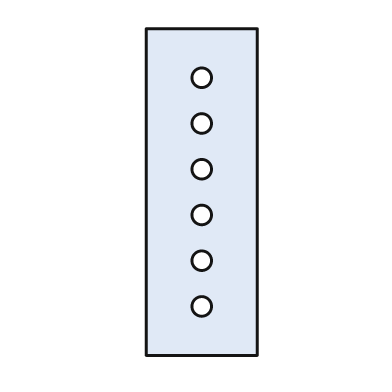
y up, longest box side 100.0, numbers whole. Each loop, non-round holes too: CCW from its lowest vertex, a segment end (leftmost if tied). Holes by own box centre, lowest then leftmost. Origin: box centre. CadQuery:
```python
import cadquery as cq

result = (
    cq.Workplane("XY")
    .moveTo(-17.0, -50.0)
    .lineTo(17.0, -50.0)
    .lineTo(17.0, 50.0)
    .lineTo(-17.0, 50.0)
    .close()
    .moveTo(0.0, -35.0)
    .circle(3.0)
    .moveTo(0.0, -21.0)
    .circle(3.0)
    .moveTo(0.0, -7.0)
    .circle(3.0)
    .moveTo(0.0, 7.0)
    .circle(3.0)
    .moveTo(0.0, 21.0)
    .circle(3.0)
    .moveTo(0.0, 35.0)
    .circle(3.0)
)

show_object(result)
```